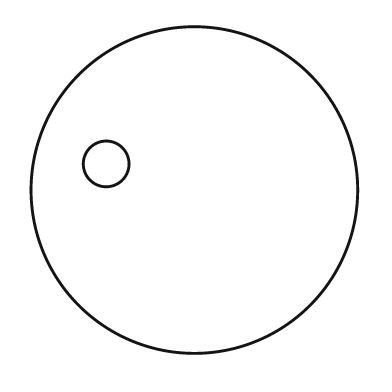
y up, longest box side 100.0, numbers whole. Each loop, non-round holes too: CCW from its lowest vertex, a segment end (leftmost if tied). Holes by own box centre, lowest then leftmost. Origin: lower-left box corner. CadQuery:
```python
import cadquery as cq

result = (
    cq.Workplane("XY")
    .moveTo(50.0, 50.0)
    .circle(50.0)
    .moveTo(23.0, 58.0)
    .circle(7.0)
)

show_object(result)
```